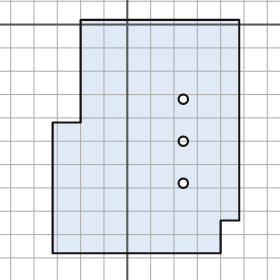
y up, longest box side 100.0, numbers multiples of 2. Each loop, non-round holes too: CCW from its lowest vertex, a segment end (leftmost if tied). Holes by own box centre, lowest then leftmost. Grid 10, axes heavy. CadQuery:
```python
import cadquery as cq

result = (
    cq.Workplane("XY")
    .moveTo(-32.0, -98.0)
    .lineTo(40.0, -98.0)
    .lineTo(40.0, -84.0)
    .lineTo(48.0, -84.0)
    .lineTo(48.0, 2.0)
    .lineTo(-20.0, 2.0)
    .lineTo(-20.0, -42.0)
    .lineTo(-32.0, -42.0)
    .close()
    .moveTo(24.0, -68.0)
    .circle(2.0)
    .moveTo(24.0, -50.0)
    .circle(2.0)
    .moveTo(24.0, -32.0)
    .circle(2.0)
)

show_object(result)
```